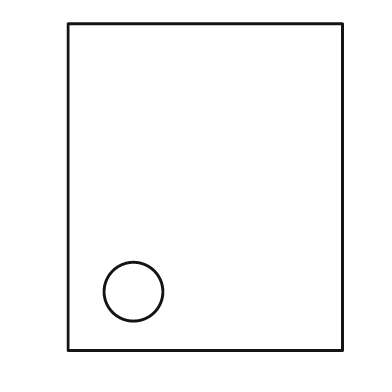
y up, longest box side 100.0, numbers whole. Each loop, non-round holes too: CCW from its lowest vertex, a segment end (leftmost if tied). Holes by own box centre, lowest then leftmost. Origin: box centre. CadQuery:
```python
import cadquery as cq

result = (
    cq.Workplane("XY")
    .moveTo(-42.0, -50.0)
    .lineTo(42.0, -50.0)
    .lineTo(42.0, 50.0)
    .lineTo(-42.0, 50.0)
    .close()
    .moveTo(-22.0, -32.0)
    .circle(9.0)
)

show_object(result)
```